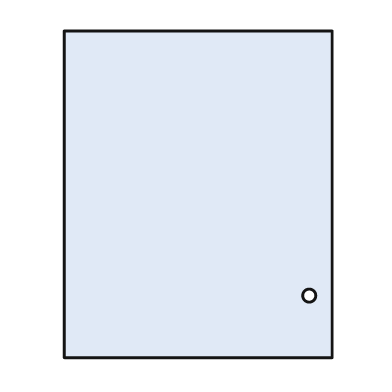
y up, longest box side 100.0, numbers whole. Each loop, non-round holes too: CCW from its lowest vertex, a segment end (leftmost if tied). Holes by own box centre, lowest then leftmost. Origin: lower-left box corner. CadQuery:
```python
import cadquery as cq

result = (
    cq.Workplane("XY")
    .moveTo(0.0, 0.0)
    .lineTo(82.0, 0.0)
    .lineTo(82.0, 100.0)
    .lineTo(0.0, 100.0)
    .close()
    .moveTo(75.0, 19.0)
    .circle(2.0)
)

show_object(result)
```